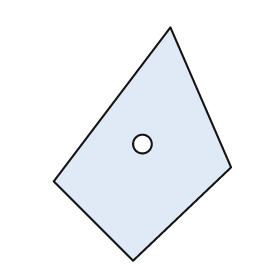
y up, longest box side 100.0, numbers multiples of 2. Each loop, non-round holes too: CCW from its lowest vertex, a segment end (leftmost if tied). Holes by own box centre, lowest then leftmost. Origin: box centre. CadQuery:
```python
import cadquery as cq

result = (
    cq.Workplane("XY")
    .moveTo(-4.0, -50.0)
    .lineTo(38.0, -10.0)
    .lineTo(12.0, 50.0)
    .lineTo(-38.0, -16.0)
    .close()
    .moveTo(0.0, 0.0)
    .circle(4.0)
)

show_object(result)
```